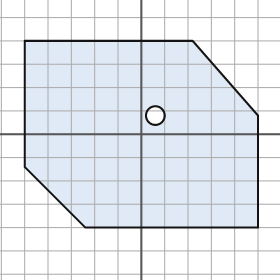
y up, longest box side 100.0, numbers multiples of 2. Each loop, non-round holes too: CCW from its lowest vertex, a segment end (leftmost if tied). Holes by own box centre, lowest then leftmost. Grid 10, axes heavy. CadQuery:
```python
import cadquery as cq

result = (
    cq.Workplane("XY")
    .moveTo(-24.0, -40.0)
    .lineTo(50.0, -40.0)
    .lineTo(50.0, 8.0)
    .lineTo(22.0, 40.0)
    .lineTo(-50.0, 40.0)
    .lineTo(-50.0, -14.0)
    .close()
    .moveTo(6.0, 8.0)
    .circle(4.0)
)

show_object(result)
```